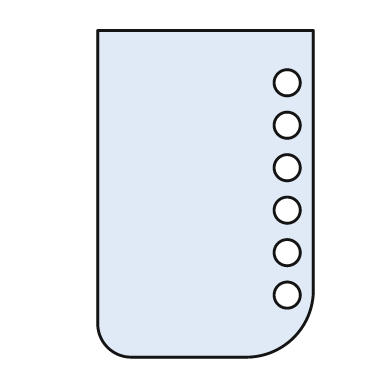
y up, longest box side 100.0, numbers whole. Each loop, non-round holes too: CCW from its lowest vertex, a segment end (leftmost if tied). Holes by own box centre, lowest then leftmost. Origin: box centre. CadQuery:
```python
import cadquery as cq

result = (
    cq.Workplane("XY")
    .moveTo(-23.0, -50.0)
    .lineTo(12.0, -50.0)
    .threePointArc((27.0, -44.0), (33.0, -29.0))
    .lineTo(33.0, 50.0)
    .lineTo(-33.0, 50.0)
    .lineTo(-33.0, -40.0)
    .threePointArc((-30.0, -47.0), (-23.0, -50.0))
    .close()
    .moveTo(25.0, -31.0)
    .circle(4.0)
    .moveTo(25.0, -18.0)
    .circle(4.0)
    .moveTo(25.0, -5.0)
    .circle(4.0)
    .moveTo(25.0, 8.0)
    .circle(4.0)
    .moveTo(25.0, 21.0)
    .circle(4.0)
    .moveTo(25.0, 34.0)
    .circle(4.0)
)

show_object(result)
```